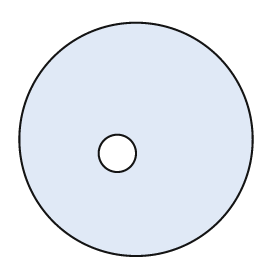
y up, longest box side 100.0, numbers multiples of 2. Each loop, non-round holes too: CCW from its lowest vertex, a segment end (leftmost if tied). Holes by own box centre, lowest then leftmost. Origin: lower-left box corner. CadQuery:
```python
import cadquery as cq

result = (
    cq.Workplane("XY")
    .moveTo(50.0, 50.0)
    .circle(50.0)
    .moveTo(42.0, 44.0)
    .circle(8.0)
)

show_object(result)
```